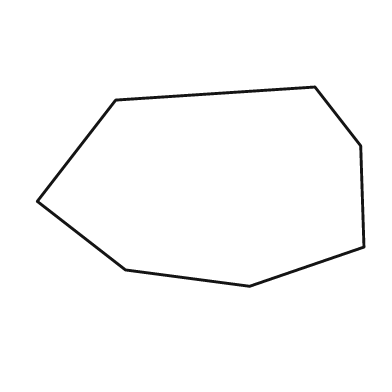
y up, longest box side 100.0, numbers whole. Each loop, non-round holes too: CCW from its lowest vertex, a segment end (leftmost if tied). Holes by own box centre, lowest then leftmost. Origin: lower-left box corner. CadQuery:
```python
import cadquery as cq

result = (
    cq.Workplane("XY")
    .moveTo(65.0, 0.0)
    .lineTo(100.0, 12.0)
    .lineTo(99.0, 43.0)
    .lineTo(85.0, 61.0)
    .lineTo(24.0, 57.0)
    .lineTo(0.0, 26.0)
    .lineTo(27.0, 5.0)
    .close()
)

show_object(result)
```